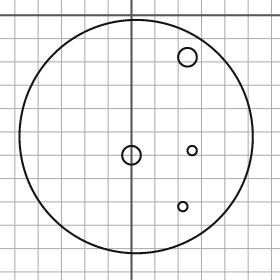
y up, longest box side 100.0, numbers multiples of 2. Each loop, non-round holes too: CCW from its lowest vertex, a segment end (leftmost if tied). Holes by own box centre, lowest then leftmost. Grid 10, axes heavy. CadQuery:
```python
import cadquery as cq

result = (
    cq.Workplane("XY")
    .moveTo(2.0, -52.0)
    .circle(50.0)
    .moveTo(22.0, -82.0)
    .circle(2.0)
    .moveTo(0.0, -60.0)
    .circle(4.0)
    .moveTo(26.0, -58.0)
    .circle(2.0)
    .moveTo(24.0, -18.0)
    .circle(4.0)
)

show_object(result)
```